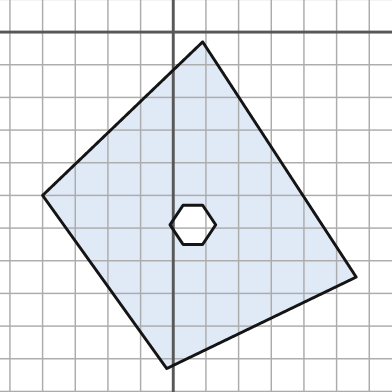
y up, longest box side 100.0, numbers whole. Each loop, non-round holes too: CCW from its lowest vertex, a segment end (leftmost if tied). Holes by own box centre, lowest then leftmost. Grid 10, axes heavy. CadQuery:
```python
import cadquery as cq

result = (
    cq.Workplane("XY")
    .moveTo(-2.0, -103.0)
    .lineTo(56.0, -75.0)
    .lineTo(9.0, -3.0)
    .lineTo(-40.0, -50.0)
    .close()
    .moveTo(3.0, -65.0)
    .lineTo(9.0, -65.0)
    .lineTo(13.0, -59.0)
    .lineTo(9.0, -53.0)
    .lineTo(3.0, -53.0)
    .lineTo(-1.0, -59.0)
    .close()
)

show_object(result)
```